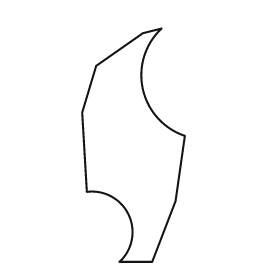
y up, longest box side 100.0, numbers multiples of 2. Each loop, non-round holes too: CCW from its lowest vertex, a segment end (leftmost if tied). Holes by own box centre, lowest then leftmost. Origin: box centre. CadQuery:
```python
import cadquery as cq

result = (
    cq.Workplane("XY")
    .moveTo(-6.0, -50.0)
    .lineTo(8.0, -50.0)
    .lineTo(18.0, -24.0)
    .lineTo(22.0, 4.0)
    .threePointArc((4.0, 24.0), (12.0, 50.0))
    .lineTo(4.0, 48.0)
    .lineTo(-16.0, 34.0)
    .lineTo(-22.0, 14.0)
    .lineTo(-20.0, -20.0)
    .threePointArc((-2.0, -30.0), (-6.0, -50.0))
    .close()
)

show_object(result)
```